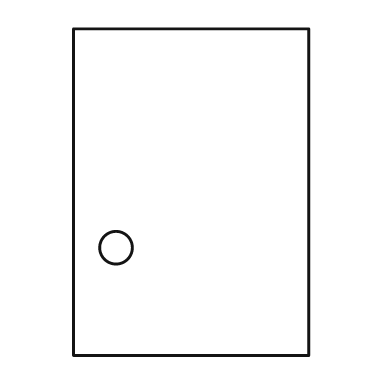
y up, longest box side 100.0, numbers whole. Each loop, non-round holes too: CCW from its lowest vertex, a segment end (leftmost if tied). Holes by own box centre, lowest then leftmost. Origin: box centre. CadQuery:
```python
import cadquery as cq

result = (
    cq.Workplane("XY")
    .moveTo(-36.0, -50.0)
    .lineTo(36.0, -50.0)
    .lineTo(36.0, 50.0)
    .lineTo(-36.0, 50.0)
    .close()
    .moveTo(-23.0, -17.0)
    .circle(5.0)
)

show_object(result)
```